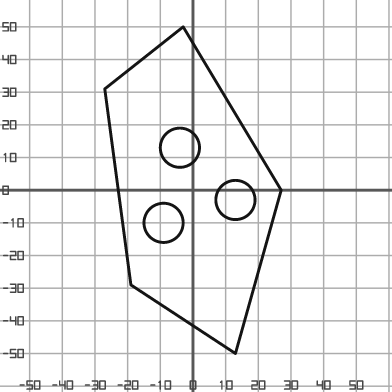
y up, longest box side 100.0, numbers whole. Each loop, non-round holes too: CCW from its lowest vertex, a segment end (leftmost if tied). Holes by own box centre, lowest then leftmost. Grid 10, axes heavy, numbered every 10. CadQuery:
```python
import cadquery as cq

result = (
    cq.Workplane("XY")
    .moveTo(13.0, -50.0)
    .lineTo(27.0, 0.0)
    .lineTo(-3.0, 50.0)
    .lineTo(-27.0, 31.0)
    .lineTo(-19.0, -29.0)
    .close()
    .moveTo(-9.0, -10.0)
    .circle(6.0)
    .moveTo(13.0, -3.0)
    .circle(6.0)
    .moveTo(-4.0, 13.0)
    .circle(6.0)
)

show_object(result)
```